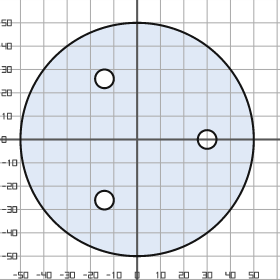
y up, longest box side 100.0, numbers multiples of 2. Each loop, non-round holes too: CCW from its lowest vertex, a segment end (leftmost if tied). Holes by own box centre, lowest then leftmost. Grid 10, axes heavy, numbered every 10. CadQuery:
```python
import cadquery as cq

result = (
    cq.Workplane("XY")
    .moveTo(0.0, 0.0)
    .circle(50.0)
    .moveTo(-14.0, -26.0)
    .circle(4.0)
    .moveTo(30.0, 0.0)
    .circle(4.0)
    .moveTo(-14.0, 26.0)
    .circle(4.0)
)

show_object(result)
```